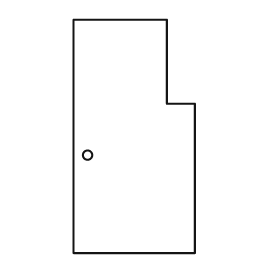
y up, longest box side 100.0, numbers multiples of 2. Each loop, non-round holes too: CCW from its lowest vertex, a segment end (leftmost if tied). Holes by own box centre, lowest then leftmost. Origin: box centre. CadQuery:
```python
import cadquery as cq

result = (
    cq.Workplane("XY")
    .moveTo(-26.0, -50.0)
    .lineTo(26.0, -50.0)
    .lineTo(26.0, 14.0)
    .lineTo(14.0, 14.0)
    .lineTo(14.0, 50.0)
    .lineTo(-26.0, 50.0)
    .close()
    .moveTo(-20.0, -8.0)
    .circle(2.0)
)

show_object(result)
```